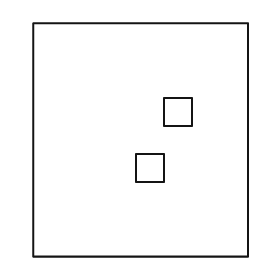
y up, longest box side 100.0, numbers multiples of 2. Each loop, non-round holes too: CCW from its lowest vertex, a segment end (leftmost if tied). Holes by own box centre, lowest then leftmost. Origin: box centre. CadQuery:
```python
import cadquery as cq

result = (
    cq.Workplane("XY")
    .moveTo(-46.0, -50.0)
    .lineTo(46.0, -50.0)
    .lineTo(46.0, 50.0)
    .lineTo(-46.0, 50.0)
    .close()
    .moveTo(-2.0, -18.0)
    .lineTo(10.0, -18.0)
    .lineTo(10.0, -6.0)
    .lineTo(-2.0, -6.0)
    .close()
    .moveTo(10.0, 6.0)
    .lineTo(22.0, 6.0)
    .lineTo(22.0, 18.0)
    .lineTo(10.0, 18.0)
    .close()
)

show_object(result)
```